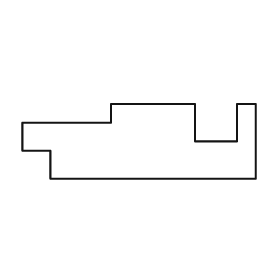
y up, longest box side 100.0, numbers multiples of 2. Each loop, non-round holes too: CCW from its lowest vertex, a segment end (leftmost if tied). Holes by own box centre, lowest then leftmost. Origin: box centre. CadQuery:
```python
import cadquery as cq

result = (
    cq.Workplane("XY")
    .moveTo(-38.0, -16.0)
    .lineTo(50.0, -16.0)
    .lineTo(50.0, 16.0)
    .lineTo(42.0, 16.0)
    .lineTo(42.0, 0.0)
    .lineTo(24.0, 0.0)
    .lineTo(24.0, 16.0)
    .lineTo(-12.0, 16.0)
    .lineTo(-12.0, 8.0)
    .lineTo(-50.0, 8.0)
    .lineTo(-50.0, -4.0)
    .lineTo(-38.0, -4.0)
    .close()
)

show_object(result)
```